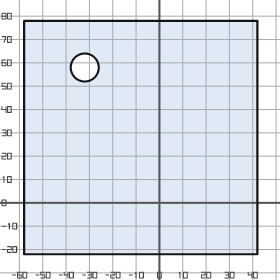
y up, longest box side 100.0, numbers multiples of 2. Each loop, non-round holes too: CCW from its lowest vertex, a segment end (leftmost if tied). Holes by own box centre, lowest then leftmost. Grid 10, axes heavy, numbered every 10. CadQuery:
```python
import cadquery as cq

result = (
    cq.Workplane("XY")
    .moveTo(-58.0, -22.0)
    .lineTo(42.0, -22.0)
    .lineTo(42.0, 78.0)
    .lineTo(-58.0, 78.0)
    .close()
    .moveTo(-32.0, 58.0)
    .circle(6.0)
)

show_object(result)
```